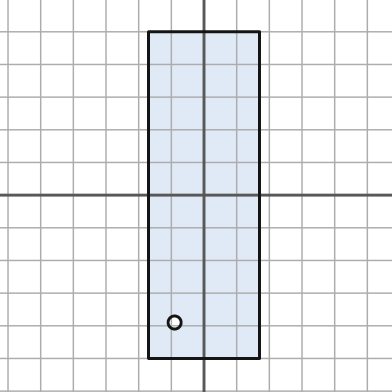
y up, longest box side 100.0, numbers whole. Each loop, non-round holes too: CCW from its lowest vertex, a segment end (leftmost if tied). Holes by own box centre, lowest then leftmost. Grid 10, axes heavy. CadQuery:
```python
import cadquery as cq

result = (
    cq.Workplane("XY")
    .moveTo(-17.0, -50.0)
    .lineTo(17.0, -50.0)
    .lineTo(17.0, 50.0)
    .lineTo(-17.0, 50.0)
    .close()
    .moveTo(-9.0, -39.0)
    .circle(2.0)
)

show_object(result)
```